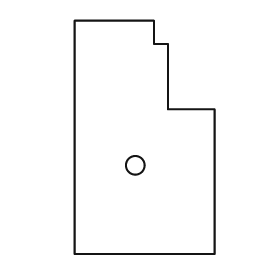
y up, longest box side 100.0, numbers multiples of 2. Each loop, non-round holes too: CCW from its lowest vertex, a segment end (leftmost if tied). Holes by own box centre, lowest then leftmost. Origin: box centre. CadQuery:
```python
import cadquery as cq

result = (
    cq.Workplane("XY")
    .moveTo(-30.0, -50.0)
    .lineTo(30.0, -50.0)
    .lineTo(30.0, 12.0)
    .lineTo(10.0, 12.0)
    .lineTo(10.0, 40.0)
    .lineTo(4.0, 40.0)
    .lineTo(4.0, 50.0)
    .lineTo(-30.0, 50.0)
    .close()
    .moveTo(-4.0, -12.0)
    .circle(4.0)
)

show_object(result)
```